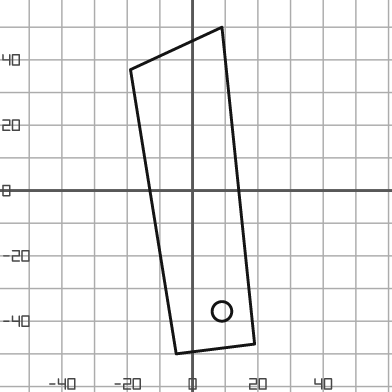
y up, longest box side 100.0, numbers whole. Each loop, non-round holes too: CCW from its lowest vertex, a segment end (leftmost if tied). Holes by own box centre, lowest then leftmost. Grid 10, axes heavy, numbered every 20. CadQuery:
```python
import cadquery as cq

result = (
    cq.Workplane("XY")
    .moveTo(-5.0, -50.0)
    .lineTo(19.0, -47.0)
    .lineTo(9.0, 50.0)
    .lineTo(-19.0, 37.0)
    .close()
    .moveTo(9.0, -37.0)
    .circle(3.0)
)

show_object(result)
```